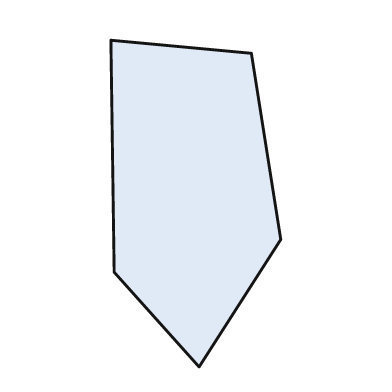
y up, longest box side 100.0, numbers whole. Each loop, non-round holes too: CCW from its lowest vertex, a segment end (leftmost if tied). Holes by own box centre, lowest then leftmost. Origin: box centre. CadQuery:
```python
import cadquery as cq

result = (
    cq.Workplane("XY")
    .moveTo(1.0, -50.0)
    .lineTo(26.0, -11.0)
    .lineTo(17.0, 46.0)
    .lineTo(-26.0, 50.0)
    .lineTo(-25.0, -21.0)
    .close()
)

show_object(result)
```